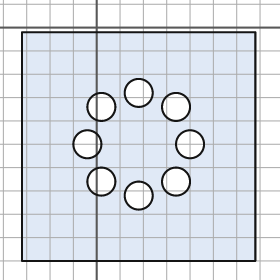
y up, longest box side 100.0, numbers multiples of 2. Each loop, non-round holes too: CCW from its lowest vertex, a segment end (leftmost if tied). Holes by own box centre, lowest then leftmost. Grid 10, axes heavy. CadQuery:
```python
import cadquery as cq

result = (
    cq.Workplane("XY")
    .moveTo(-32.0, -100.0)
    .lineTo(68.0, -100.0)
    .lineTo(68.0, -2.0)
    .lineTo(-32.0, -2.0)
    .close()
    .moveTo(18.0, -72.0)
    .circle(6.0)
    .moveTo(2.0, -66.0)
    .circle(6.0)
    .moveTo(34.0, -66.0)
    .circle(6.0)
    .moveTo(-4.0, -50.0)
    .circle(6.0)
    .moveTo(40.0, -50.0)
    .circle(6.0)
    .moveTo(2.0, -34.0)
    .circle(6.0)
    .moveTo(34.0, -34.0)
    .circle(6.0)
    .moveTo(18.0, -28.0)
    .circle(6.0)
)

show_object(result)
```